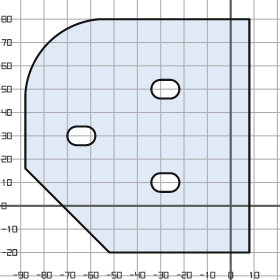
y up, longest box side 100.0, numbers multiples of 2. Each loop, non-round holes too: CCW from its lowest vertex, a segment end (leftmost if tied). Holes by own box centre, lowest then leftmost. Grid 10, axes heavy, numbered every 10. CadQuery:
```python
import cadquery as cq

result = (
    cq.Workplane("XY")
    .moveTo(-52.0, -20.0)
    .lineTo(8.0, -20.0)
    .lineTo(8.0, 80.0)
    .lineTo(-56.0, 80.0)
    .threePointArc((-78.0, 70.0), (-88.0, 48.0))
    .lineTo(-88.0, 16.0)
    .close()
    .moveTo(-30.0, 6.0)
    .lineTo(-26.0, 6.0)
    .threePointArc((-22.0, 10.0), (-26.0, 14.0))
    .lineTo(-30.0, 14.0)
    .threePointArc((-34.0, 10.0), (-30.0, 6.0))
    .close()
    .moveTo(-66.0, 26.0)
    .lineTo(-62.0, 26.0)
    .threePointArc((-58.0, 30.0), (-62.0, 34.0))
    .lineTo(-66.0, 34.0)
    .threePointArc((-70.0, 30.0), (-66.0, 26.0))
    .close()
    .moveTo(-30.0, 46.0)
    .lineTo(-26.0, 46.0)
    .threePointArc((-22.0, 50.0), (-26.0, 54.0))
    .lineTo(-30.0, 54.0)
    .threePointArc((-34.0, 50.0), (-30.0, 46.0))
    .close()
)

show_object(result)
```